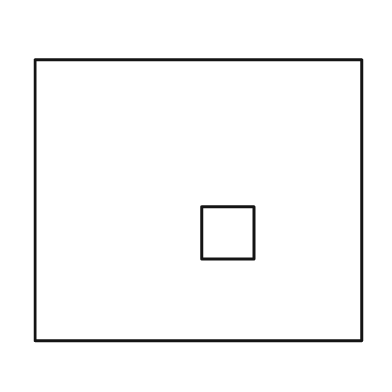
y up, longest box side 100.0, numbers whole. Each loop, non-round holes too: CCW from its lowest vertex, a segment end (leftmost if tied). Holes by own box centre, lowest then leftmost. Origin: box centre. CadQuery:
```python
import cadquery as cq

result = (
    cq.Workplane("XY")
    .moveTo(-50.0, -43.0)
    .lineTo(50.0, -43.0)
    .lineTo(50.0, 43.0)
    .lineTo(-50.0, 43.0)
    .close()
    .moveTo(1.0, -18.0)
    .lineTo(17.0, -18.0)
    .lineTo(17.0, -2.0)
    .lineTo(1.0, -2.0)
    .close()
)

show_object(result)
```